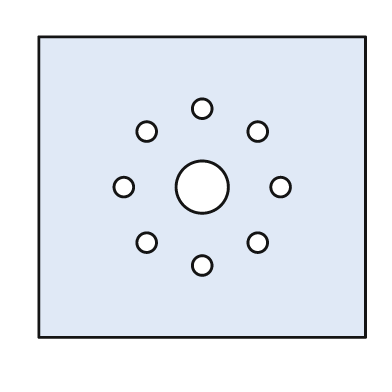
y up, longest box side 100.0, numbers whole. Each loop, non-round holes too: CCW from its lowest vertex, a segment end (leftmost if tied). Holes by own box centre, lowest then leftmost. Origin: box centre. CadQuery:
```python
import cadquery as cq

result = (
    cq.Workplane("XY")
    .moveTo(-50.0, -46.0)
    .lineTo(50.0, -46.0)
    .lineTo(50.0, 46.0)
    .lineTo(-50.0, 46.0)
    .close()
    .moveTo(0.0, -24.0)
    .circle(3.0)
    .moveTo(-17.0, -17.0)
    .circle(3.0)
    .moveTo(17.0, -17.0)
    .circle(3.0)
    .moveTo(-24.0, 0.0)
    .circle(3.0)
    .moveTo(0.0, 0.0)
    .circle(8.0)
    .moveTo(24.0, 0.0)
    .circle(3.0)
    .moveTo(-17.0, 17.0)
    .circle(3.0)
    .moveTo(17.0, 17.0)
    .circle(3.0)
    .moveTo(0.0, 24.0)
    .circle(3.0)
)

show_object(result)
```